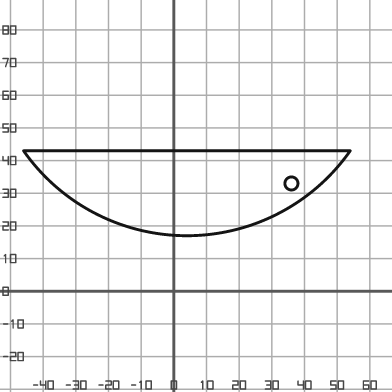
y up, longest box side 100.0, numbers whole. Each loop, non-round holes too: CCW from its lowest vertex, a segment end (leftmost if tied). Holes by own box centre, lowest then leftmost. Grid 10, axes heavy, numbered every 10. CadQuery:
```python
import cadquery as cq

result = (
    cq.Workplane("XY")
    .moveTo(-46.0, 43.0)
    .threePointArc((4.0, 17.0), (54.0, 43.0))
    .close()
    .moveTo(36.0, 33.0)
    .circle(2.0)
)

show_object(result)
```